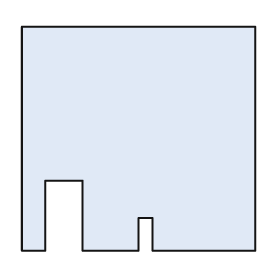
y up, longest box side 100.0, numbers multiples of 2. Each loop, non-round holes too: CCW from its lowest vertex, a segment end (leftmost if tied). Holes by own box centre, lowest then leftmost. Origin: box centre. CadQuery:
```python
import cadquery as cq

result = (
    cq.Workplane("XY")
    .moveTo(-50.0, -48.0)
    .lineTo(-40.0, -48.0)
    .lineTo(-40.0, -18.0)
    .lineTo(-24.0, -18.0)
    .lineTo(-24.0, -48.0)
    .lineTo(0.0, -48.0)
    .lineTo(0.0, -34.0)
    .lineTo(6.0, -34.0)
    .lineTo(6.0, -48.0)
    .lineTo(50.0, -48.0)
    .lineTo(50.0, 48.0)
    .lineTo(-50.0, 48.0)
    .close()
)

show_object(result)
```